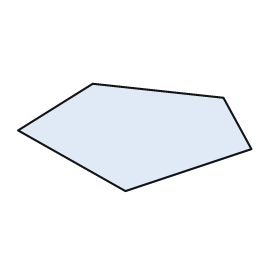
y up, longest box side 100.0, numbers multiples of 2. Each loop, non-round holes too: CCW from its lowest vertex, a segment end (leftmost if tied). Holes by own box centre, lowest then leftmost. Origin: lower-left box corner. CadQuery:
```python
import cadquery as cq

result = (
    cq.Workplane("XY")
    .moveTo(46.0, 0.0)
    .lineTo(100.0, 18.0)
    .lineTo(88.0, 40.0)
    .lineTo(32.0, 46.0)
    .lineTo(0.0, 26.0)
    .close()
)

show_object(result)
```